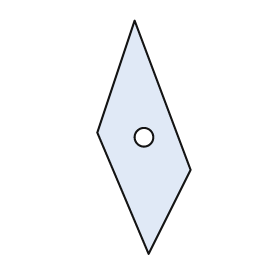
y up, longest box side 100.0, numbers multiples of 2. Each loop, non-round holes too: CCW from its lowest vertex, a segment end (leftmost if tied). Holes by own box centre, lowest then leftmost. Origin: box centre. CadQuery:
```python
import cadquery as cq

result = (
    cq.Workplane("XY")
    .moveTo(2.0, -50.0)
    .lineTo(20.0, -14.0)
    .lineTo(-4.0, 50.0)
    .lineTo(-20.0, 2.0)
    .close()
    .moveTo(0.0, 0.0)
    .circle(4.0)
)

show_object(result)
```